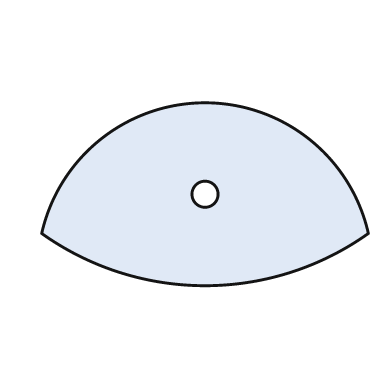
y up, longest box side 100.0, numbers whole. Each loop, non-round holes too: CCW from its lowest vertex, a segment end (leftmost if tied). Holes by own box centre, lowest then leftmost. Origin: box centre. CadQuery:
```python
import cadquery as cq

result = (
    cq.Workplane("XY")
    .moveTo(-50.0, -12.0)
    .threePointArc((0.0, -28.0), (50.0, -12.0))
    .threePointArc((0.0, 28.0), (-50.0, -12.0))
    .close()
    .moveTo(0.0, 0.0)
    .circle(4.0)
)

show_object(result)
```